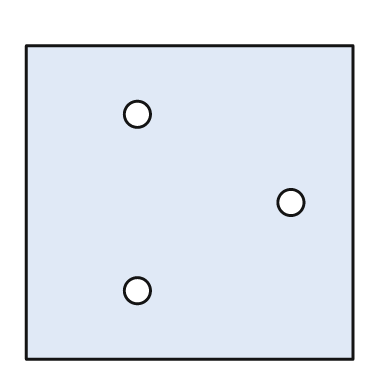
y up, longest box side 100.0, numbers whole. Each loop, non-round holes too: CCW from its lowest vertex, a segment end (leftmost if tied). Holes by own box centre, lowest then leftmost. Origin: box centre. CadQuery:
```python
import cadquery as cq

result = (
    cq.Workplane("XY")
    .moveTo(-50.0, -48.0)
    .lineTo(50.0, -48.0)
    .lineTo(50.0, 48.0)
    .lineTo(-50.0, 48.0)
    .close()
    .moveTo(-16.0, -27.0)
    .circle(4.0)
    .moveTo(31.0, 0.0)
    .circle(4.0)
    .moveTo(-16.0, 27.0)
    .circle(4.0)
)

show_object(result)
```